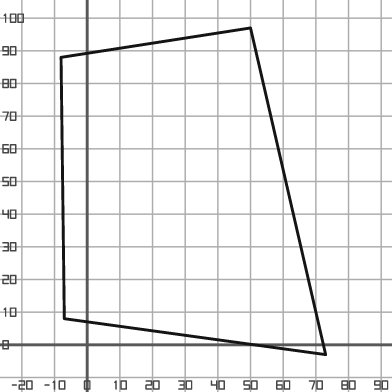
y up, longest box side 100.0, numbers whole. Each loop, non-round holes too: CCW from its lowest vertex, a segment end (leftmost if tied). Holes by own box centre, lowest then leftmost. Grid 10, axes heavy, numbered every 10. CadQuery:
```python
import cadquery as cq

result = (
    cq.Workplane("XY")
    .moveTo(73.0, -3.0)
    .lineTo(50.0, 97.0)
    .lineTo(-8.0, 88.0)
    .lineTo(-7.0, 8.0)
    .close()
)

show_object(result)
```